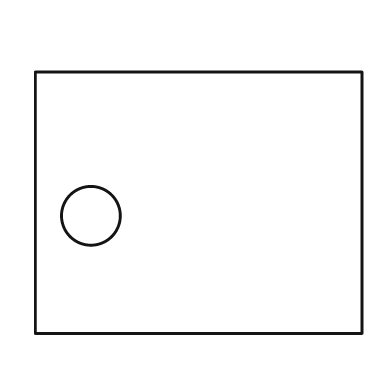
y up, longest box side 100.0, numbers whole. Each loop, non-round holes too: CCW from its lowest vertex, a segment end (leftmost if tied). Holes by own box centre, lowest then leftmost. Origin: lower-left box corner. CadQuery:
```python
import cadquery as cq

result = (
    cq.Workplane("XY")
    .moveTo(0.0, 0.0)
    .lineTo(100.0, 0.0)
    .lineTo(100.0, 80.0)
    .lineTo(0.0, 80.0)
    .close()
    .moveTo(17.0, 36.0)
    .circle(9.0)
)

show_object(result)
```